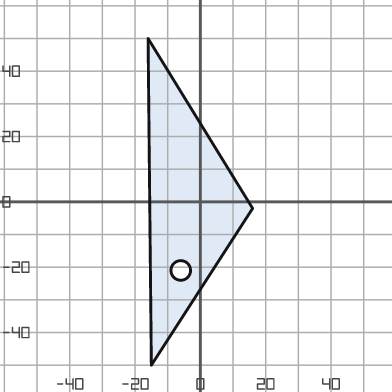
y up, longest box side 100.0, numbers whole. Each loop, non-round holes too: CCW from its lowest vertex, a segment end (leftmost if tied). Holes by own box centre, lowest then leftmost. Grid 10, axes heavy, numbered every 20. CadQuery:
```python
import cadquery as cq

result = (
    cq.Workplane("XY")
    .moveTo(-15.0, -50.0)
    .lineTo(16.0, -2.0)
    .lineTo(-16.0, 50.0)
    .close()
    .moveTo(-6.0, -21.0)
    .circle(3.0)
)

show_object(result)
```